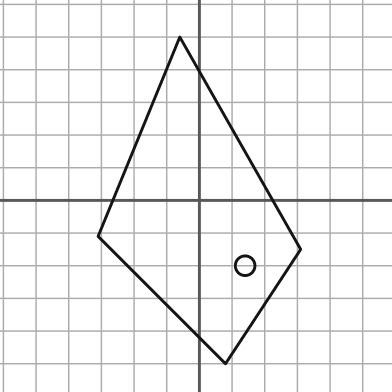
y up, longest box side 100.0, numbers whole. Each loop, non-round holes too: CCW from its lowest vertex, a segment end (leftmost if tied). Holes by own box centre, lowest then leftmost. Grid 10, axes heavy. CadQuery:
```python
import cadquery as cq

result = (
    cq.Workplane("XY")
    .moveTo(8.0, -50.0)
    .lineTo(31.0, -15.0)
    .lineTo(-6.0, 50.0)
    .lineTo(-31.0, -11.0)
    .close()
    .moveTo(14.0, -20.0)
    .circle(3.0)
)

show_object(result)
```